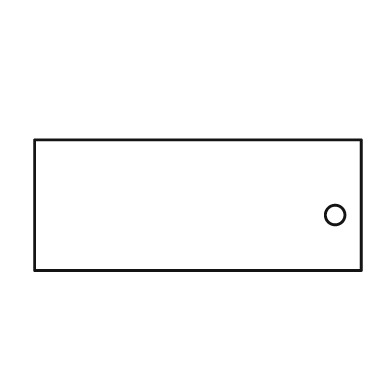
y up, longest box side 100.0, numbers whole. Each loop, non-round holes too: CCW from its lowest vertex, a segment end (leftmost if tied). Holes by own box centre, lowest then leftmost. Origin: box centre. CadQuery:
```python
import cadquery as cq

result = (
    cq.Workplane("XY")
    .moveTo(-50.0, -20.0)
    .lineTo(50.0, -20.0)
    .lineTo(50.0, 20.0)
    .lineTo(-50.0, 20.0)
    .close()
    .moveTo(42.0, -3.0)
    .circle(3.0)
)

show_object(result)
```